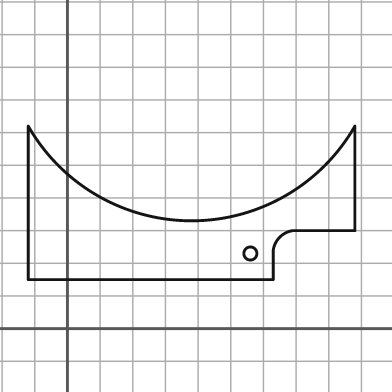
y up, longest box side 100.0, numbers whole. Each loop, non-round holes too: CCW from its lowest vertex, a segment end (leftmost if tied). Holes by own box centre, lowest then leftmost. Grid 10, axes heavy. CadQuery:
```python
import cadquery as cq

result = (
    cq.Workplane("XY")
    .moveTo(-12.0, 15.0)
    .lineTo(63.0, 15.0)
    .lineTo(63.0, 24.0)
    .threePointArc((65.0, 28.0), (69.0, 30.0))
    .lineTo(88.0, 30.0)
    .lineTo(88.0, 62.0)
    .threePointArc((38.0, 33.0), (-12.0, 62.0))
    .close()
    .moveTo(56.0, 23.0)
    .circle(2.0)
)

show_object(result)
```